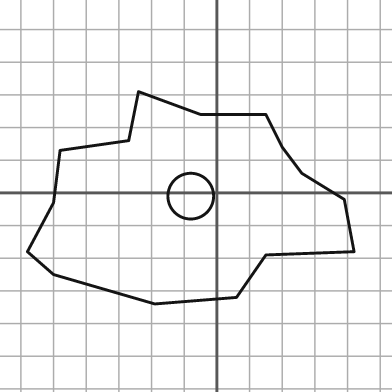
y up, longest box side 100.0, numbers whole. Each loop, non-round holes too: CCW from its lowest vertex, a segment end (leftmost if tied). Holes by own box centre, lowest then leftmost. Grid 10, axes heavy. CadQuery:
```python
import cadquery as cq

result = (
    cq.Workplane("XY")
    .moveTo(-19.0, -34.0)
    .lineTo(6.0, -32.0)
    .lineTo(15.0, -19.0)
    .lineTo(42.0, -18.0)
    .lineTo(39.0, -2.0)
    .lineTo(26.0, 6.0)
    .lineTo(20.0, 14.0)
    .lineTo(15.0, 24.0)
    .lineTo(-5.0, 24.0)
    .lineTo(-24.0, 31.0)
    .lineTo(-27.0, 16.0)
    .lineTo(-48.0, 13.0)
    .lineTo(-50.0, -3.0)
    .lineTo(-58.0, -18.0)
    .lineTo(-50.0, -25.0)
    .close()
    .moveTo(-8.0, -1.0)
    .circle(7.0)
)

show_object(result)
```